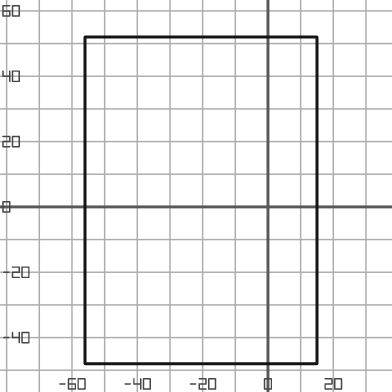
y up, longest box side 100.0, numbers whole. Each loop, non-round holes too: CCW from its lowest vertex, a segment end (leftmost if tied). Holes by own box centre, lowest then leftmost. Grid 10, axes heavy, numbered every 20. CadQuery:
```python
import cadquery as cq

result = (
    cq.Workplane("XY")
    .moveTo(-56.0, -48.0)
    .lineTo(15.0, -48.0)
    .lineTo(15.0, 52.0)
    .lineTo(-56.0, 52.0)
    .close()
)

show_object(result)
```